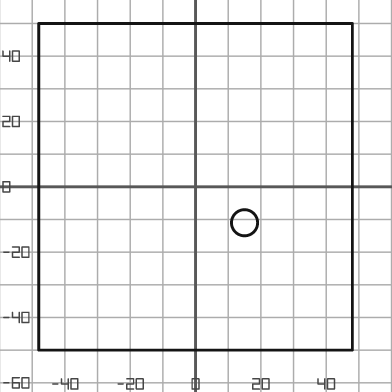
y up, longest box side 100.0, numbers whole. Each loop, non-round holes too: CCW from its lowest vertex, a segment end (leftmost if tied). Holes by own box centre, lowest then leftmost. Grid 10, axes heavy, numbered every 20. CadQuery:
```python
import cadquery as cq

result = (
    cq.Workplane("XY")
    .moveTo(-48.0, -50.0)
    .lineTo(48.0, -50.0)
    .lineTo(48.0, 50.0)
    .lineTo(-48.0, 50.0)
    .close()
    .moveTo(15.0, -11.0)
    .circle(4.0)
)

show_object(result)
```